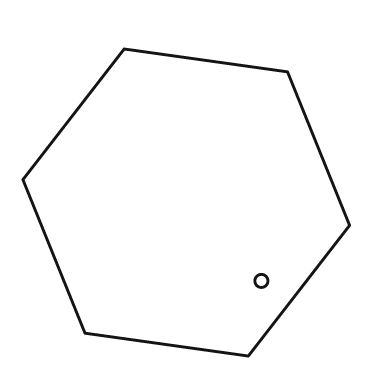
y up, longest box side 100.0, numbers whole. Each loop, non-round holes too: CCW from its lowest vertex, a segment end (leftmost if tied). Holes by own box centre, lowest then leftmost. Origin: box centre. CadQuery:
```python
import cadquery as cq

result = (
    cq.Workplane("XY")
    .moveTo(19.0, -47.0)
    .lineTo(50.0, -7.0)
    .lineTo(31.0, 40.0)
    .lineTo(-19.0, 47.0)
    .lineTo(-50.0, 7.0)
    .lineTo(-31.0, -40.0)
    .close()
    .moveTo(23.0, -24.0)
    .circle(2.0)
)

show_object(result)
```